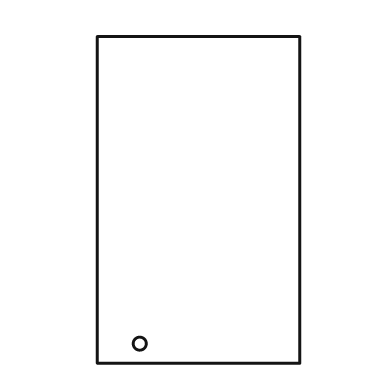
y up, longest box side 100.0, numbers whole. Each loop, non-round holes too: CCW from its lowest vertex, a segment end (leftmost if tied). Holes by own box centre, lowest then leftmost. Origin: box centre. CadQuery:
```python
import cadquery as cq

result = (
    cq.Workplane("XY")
    .moveTo(-31.0, -50.0)
    .lineTo(31.0, -50.0)
    .lineTo(31.0, 50.0)
    .lineTo(-31.0, 50.0)
    .close()
    .moveTo(-18.0, -44.0)
    .circle(2.0)
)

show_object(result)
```